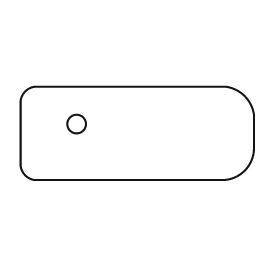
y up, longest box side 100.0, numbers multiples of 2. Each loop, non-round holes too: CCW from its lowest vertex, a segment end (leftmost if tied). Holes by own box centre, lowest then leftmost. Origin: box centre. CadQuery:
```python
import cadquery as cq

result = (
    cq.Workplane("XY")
    .moveTo(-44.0, -20.0)
    .lineTo(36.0, -20.0)
    .threePointArc((46.0, -16.0), (50.0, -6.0))
    .lineTo(50.0, 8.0)
    .threePointArc((46.0, 16.0), (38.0, 20.0))
    .lineTo(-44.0, 20.0)
    .threePointArc((-48.0, 18.0), (-50.0, 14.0))
    .lineTo(-50.0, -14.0)
    .threePointArc((-48.0, -18.0), (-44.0, -20.0))
    .close()
    .moveTo(-26.0, 4.0)
    .circle(4.0)
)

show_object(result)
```